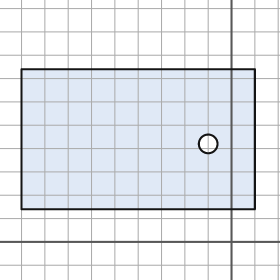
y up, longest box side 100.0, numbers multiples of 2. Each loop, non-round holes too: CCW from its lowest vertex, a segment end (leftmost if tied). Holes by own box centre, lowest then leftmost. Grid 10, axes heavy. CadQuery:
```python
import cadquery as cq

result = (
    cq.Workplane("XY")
    .moveTo(-90.0, 14.0)
    .lineTo(10.0, 14.0)
    .lineTo(10.0, 74.0)
    .lineTo(-90.0, 74.0)
    .close()
    .moveTo(-10.0, 42.0)
    .circle(4.0)
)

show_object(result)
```